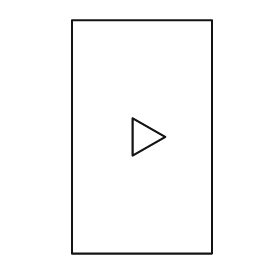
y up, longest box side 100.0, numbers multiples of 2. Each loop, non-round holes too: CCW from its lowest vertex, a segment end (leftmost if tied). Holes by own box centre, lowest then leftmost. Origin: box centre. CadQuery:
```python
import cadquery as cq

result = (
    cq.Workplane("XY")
    .moveTo(-30.0, -50.0)
    .lineTo(30.0, -50.0)
    .lineTo(30.0, 50.0)
    .lineTo(-30.0, 50.0)
    .close()
    .moveTo(-4.0, -8.0)
    .lineTo(10.0, 0.0)
    .lineTo(-4.0, 8.0)
    .close()
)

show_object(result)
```